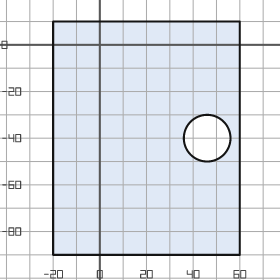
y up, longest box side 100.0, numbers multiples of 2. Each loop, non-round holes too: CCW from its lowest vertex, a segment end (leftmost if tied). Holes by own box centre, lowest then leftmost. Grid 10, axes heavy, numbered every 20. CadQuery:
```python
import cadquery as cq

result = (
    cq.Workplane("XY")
    .moveTo(-20.0, -90.0)
    .lineTo(60.0, -90.0)
    .lineTo(60.0, 10.0)
    .lineTo(-20.0, 10.0)
    .close()
    .moveTo(46.0, -40.0)
    .circle(10.0)
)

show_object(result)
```